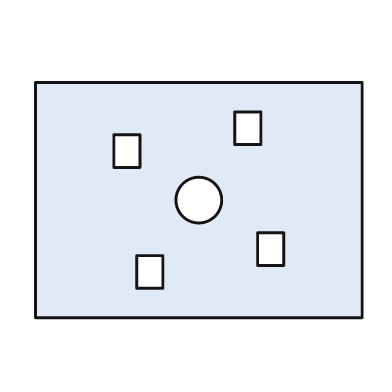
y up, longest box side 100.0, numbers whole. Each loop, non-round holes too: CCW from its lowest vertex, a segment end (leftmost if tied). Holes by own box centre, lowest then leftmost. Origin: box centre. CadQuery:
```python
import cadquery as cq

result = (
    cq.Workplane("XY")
    .moveTo(-50.0, -36.0)
    .lineTo(50.0, -36.0)
    .lineTo(50.0, 36.0)
    .lineTo(-50.0, 36.0)
    .close()
    .moveTo(-19.0, -27.0)
    .lineTo(-11.0, -27.0)
    .lineTo(-11.0, -17.0)
    .lineTo(-19.0, -17.0)
    .close()
    .moveTo(18.0, -20.0)
    .lineTo(26.0, -20.0)
    .lineTo(26.0, -10.0)
    .lineTo(18.0, -10.0)
    .close()
    .moveTo(0.0, 0.0)
    .circle(7.0)
    .moveTo(-26.0, 10.0)
    .lineTo(-18.0, 10.0)
    .lineTo(-18.0, 20.0)
    .lineTo(-26.0, 20.0)
    .close()
    .moveTo(11.0, 17.0)
    .lineTo(19.0, 17.0)
    .lineTo(19.0, 27.0)
    .lineTo(11.0, 27.0)
    .close()
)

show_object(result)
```